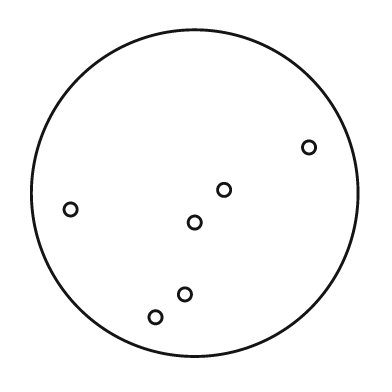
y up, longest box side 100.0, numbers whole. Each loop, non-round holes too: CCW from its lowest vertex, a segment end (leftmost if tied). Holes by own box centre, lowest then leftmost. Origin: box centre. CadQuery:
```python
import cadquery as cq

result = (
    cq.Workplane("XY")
    .moveTo(0.0, 0.0)
    .circle(50.0)
    .moveTo(-12.0, -38.0)
    .circle(2.0)
    .moveTo(-3.0, -31.0)
    .circle(2.0)
    .moveTo(0.0, -9.0)
    .circle(2.0)
    .moveTo(-38.0, -5.0)
    .circle(2.0)
    .moveTo(9.0, 1.0)
    .circle(2.0)
    .moveTo(35.0, 14.0)
    .circle(2.0)
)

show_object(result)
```